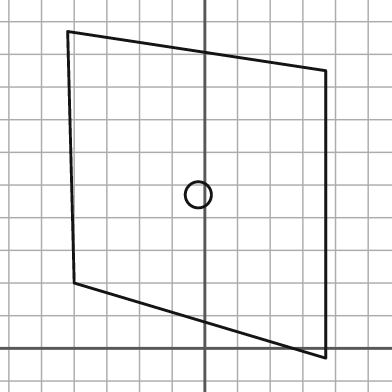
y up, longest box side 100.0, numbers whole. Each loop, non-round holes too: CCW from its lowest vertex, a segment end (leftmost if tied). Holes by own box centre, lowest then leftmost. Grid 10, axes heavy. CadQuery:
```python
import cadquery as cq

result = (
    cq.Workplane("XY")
    .moveTo(37.0, -3.0)
    .lineTo(37.0, 85.0)
    .lineTo(-42.0, 97.0)
    .lineTo(-40.0, 20.0)
    .close()
    .moveTo(-2.0, 47.0)
    .circle(4.0)
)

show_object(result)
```